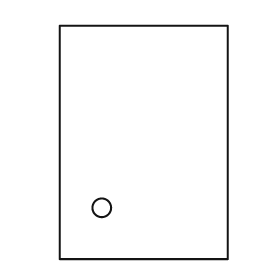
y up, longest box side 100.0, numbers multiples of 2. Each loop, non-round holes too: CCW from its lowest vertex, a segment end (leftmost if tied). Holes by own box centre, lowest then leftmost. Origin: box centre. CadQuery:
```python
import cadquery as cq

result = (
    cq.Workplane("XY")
    .moveTo(-36.0, -50.0)
    .lineTo(36.0, -50.0)
    .lineTo(36.0, 50.0)
    .lineTo(-36.0, 50.0)
    .close()
    .moveTo(-18.0, -28.0)
    .circle(4.0)
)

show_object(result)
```